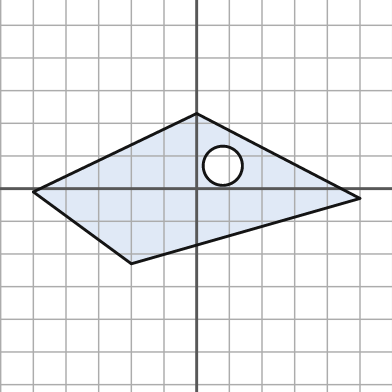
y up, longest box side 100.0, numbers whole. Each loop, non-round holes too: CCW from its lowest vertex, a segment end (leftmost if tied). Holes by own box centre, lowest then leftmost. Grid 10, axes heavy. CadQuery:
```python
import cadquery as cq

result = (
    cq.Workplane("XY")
    .moveTo(-20.0, -23.0)
    .lineTo(50.0, -3.0)
    .lineTo(0.0, 23.0)
    .lineTo(-50.0, -1.0)
    .close()
    .moveTo(8.0, 7.0)
    .circle(6.0)
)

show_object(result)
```